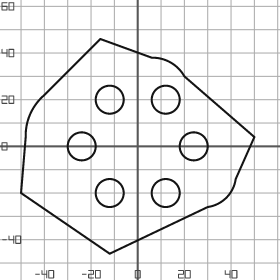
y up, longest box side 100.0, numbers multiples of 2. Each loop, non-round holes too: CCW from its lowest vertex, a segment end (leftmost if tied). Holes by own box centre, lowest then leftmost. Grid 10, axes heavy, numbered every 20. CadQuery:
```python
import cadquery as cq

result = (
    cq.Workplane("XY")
    .moveTo(-12.0, -46.0)
    .lineTo(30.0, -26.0)
    .threePointArc((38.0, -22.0), (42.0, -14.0))
    .lineTo(50.0, 4.0)
    .lineTo(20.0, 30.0)
    .threePointArc((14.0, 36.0), (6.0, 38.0))
    .lineTo(-16.0, 46.0)
    .lineTo(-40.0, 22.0)
    .threePointArc((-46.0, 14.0), (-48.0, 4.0))
    .lineTo(-50.0, -20.0)
    .close()
    .moveTo(-12.0, -20.0)
    .circle(6.0)
    .moveTo(12.0, -20.0)
    .circle(6.0)
    .moveTo(-24.0, 0.0)
    .circle(6.0)
    .moveTo(24.0, 0.0)
    .circle(6.0)
    .moveTo(-12.0, 20.0)
    .circle(6.0)
    .moveTo(12.0, 20.0)
    .circle(6.0)
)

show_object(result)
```